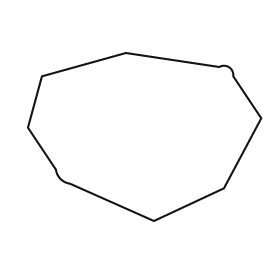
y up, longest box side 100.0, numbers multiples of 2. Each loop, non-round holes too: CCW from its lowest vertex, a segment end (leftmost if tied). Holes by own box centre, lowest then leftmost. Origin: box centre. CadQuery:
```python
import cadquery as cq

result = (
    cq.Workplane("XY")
    .moveTo(4.0, -36.0)
    .lineTo(34.0, -22.0)
    .lineTo(50.0, 8.0)
    .lineTo(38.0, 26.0)
    .threePointArc((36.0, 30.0), (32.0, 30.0))
    .lineTo(-8.0, 36.0)
    .lineTo(-44.0, 26.0)
    .lineTo(-50.0, 4.0)
    .lineTo(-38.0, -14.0)
    .threePointArc((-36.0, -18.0), (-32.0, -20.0))
    .close()
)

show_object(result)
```